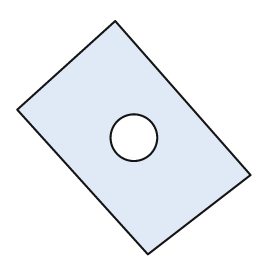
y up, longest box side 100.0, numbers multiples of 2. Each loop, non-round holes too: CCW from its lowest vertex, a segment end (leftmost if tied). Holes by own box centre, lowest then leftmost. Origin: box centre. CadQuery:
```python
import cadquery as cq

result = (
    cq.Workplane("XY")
    .moveTo(6.0, -50.0)
    .lineTo(50.0, -16.0)
    .lineTo(-8.0, 50.0)
    .lineTo(-50.0, 12.0)
    .close()
    .moveTo(0.0, 0.0)
    .circle(10.0)
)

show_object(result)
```